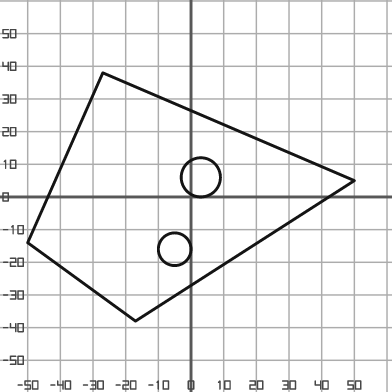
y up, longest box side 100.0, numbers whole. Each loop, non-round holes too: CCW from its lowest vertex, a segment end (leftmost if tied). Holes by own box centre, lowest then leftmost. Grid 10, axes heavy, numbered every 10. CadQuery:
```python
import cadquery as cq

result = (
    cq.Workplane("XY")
    .moveTo(-17.0, -38.0)
    .lineTo(50.0, 5.0)
    .lineTo(-27.0, 38.0)
    .lineTo(-50.0, -14.0)
    .close()
    .moveTo(-5.0, -16.0)
    .circle(5.0)
    .moveTo(3.0, 6.0)
    .circle(6.0)
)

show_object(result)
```